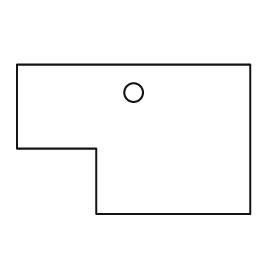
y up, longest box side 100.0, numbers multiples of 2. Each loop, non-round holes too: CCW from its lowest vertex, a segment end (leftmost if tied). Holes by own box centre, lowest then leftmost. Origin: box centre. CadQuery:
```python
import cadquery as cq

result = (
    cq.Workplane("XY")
    .moveTo(-16.0, -32.0)
    .lineTo(50.0, -32.0)
    .lineTo(50.0, 32.0)
    .lineTo(-50.0, 32.0)
    .lineTo(-50.0, -4.0)
    .lineTo(-16.0, -4.0)
    .close()
    .moveTo(0.0, 20.0)
    .circle(4.0)
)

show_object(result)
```